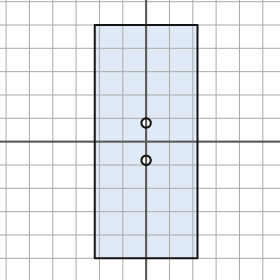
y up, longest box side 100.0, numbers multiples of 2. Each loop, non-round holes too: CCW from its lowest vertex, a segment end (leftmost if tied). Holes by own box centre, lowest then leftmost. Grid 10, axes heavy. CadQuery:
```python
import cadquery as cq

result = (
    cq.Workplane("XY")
    .moveTo(-22.0, -50.0)
    .lineTo(22.0, -50.0)
    .lineTo(22.0, 50.0)
    .lineTo(-22.0, 50.0)
    .close()
    .moveTo(0.0, -8.0)
    .circle(2.0)
    .moveTo(0.0, 8.0)
    .circle(2.0)
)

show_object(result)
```